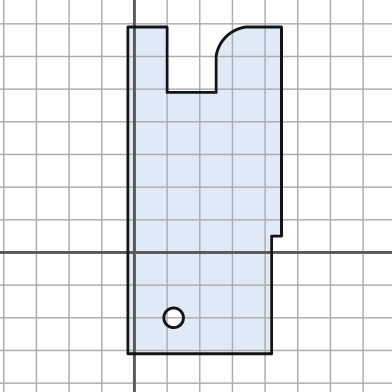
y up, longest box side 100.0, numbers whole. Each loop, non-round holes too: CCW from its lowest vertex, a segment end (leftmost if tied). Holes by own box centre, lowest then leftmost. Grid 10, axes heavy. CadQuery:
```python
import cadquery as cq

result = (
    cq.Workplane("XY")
    .moveTo(-2.0, -31.0)
    .lineTo(42.0, -31.0)
    .lineTo(42.0, 5.0)
    .lineTo(45.0, 5.0)
    .lineTo(45.0, 69.0)
    .lineTo(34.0, 69.0)
    .threePointArc((28.0, 66.0), (25.0, 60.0))
    .lineTo(25.0, 49.0)
    .lineTo(10.0, 49.0)
    .lineTo(10.0, 69.0)
    .lineTo(-2.0, 69.0)
    .close()
    .moveTo(12.0, -20.0)
    .circle(3.0)
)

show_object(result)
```